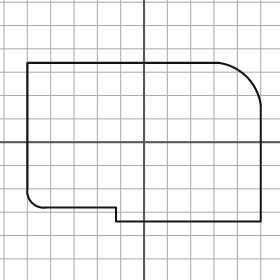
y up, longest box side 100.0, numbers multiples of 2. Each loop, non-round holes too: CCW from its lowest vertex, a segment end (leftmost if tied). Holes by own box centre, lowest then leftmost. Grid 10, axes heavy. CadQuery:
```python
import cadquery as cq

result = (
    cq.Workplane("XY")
    .moveTo(-12.0, -34.0)
    .lineTo(50.0, -34.0)
    .lineTo(50.0, 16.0)
    .threePointArc((44.0, 28.0), (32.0, 34.0))
    .lineTo(-50.0, 34.0)
    .lineTo(-50.0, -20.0)
    .threePointArc((-48.0, -26.0), (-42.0, -28.0))
    .lineTo(-12.0, -28.0)
    .close()
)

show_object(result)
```